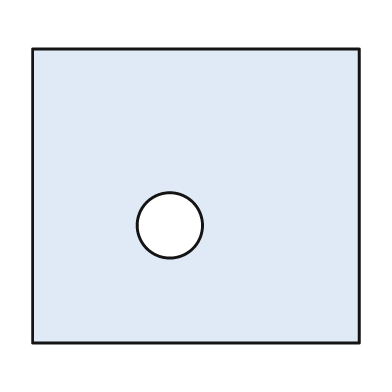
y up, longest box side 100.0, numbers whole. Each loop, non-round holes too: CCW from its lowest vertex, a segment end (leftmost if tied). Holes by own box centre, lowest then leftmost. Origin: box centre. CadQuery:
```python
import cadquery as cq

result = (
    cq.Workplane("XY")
    .moveTo(-50.0, -45.0)
    .lineTo(50.0, -45.0)
    .lineTo(50.0, 45.0)
    .lineTo(-50.0, 45.0)
    .close()
    .moveTo(-8.0, -9.0)
    .circle(10.0)
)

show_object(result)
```